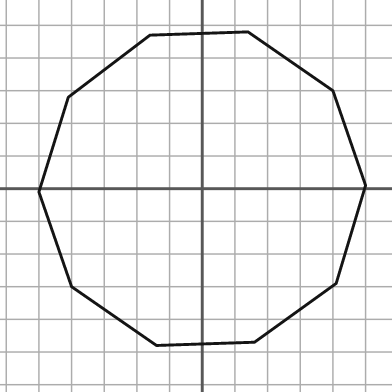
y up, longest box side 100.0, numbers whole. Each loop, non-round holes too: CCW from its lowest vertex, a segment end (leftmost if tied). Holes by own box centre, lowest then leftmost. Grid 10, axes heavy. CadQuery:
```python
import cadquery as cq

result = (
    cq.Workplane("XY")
    .moveTo(-14.0, -48.0)
    .lineTo(16.0, -47.0)
    .lineTo(41.0, -29.0)
    .lineTo(50.0, 1.0)
    .lineTo(40.0, 30.0)
    .lineTo(14.0, 48.0)
    .lineTo(-16.0, 47.0)
    .lineTo(-41.0, 28.0)
    .lineTo(-50.0, -1.0)
    .lineTo(-40.0, -30.0)
    .close()
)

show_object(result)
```